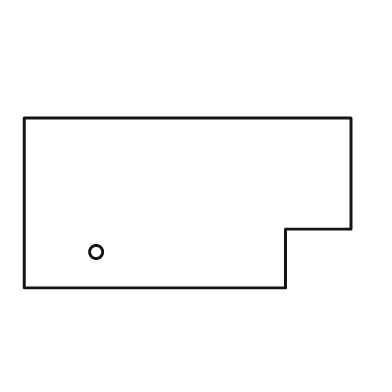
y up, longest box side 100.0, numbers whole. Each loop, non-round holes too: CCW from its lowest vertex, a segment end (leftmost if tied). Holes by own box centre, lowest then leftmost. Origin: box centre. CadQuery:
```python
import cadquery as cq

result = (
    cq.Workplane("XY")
    .moveTo(-50.0, -26.0)
    .lineTo(30.0, -26.0)
    .lineTo(30.0, -8.0)
    .lineTo(50.0, -8.0)
    .lineTo(50.0, 26.0)
    .lineTo(-50.0, 26.0)
    .close()
    .moveTo(-28.0, -15.0)
    .circle(2.0)
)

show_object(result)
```